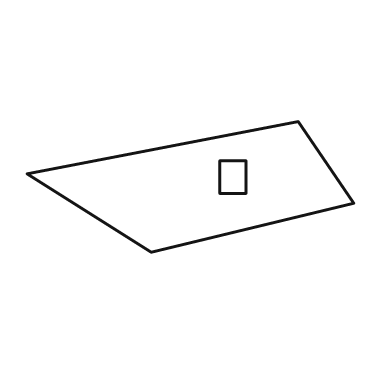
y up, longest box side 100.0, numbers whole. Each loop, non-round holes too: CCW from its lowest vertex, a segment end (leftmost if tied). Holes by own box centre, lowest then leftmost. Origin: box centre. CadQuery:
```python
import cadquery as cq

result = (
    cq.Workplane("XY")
    .moveTo(-12.0, -20.0)
    .lineTo(50.0, -5.0)
    .lineTo(33.0, 20.0)
    .lineTo(-50.0, 4.0)
    .close()
    .moveTo(9.0, -2.0)
    .lineTo(17.0, -2.0)
    .lineTo(17.0, 8.0)
    .lineTo(9.0, 8.0)
    .close()
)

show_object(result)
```